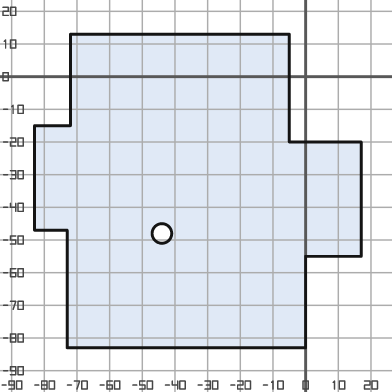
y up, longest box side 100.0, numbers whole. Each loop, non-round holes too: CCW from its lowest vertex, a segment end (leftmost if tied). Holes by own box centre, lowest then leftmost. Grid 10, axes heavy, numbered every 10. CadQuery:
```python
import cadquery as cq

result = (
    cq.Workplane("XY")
    .moveTo(-73.0, -83.0)
    .lineTo(0.0, -83.0)
    .lineTo(0.0, -55.0)
    .lineTo(17.0, -55.0)
    .lineTo(17.0, -20.0)
    .lineTo(-5.0, -20.0)
    .lineTo(-5.0, 13.0)
    .lineTo(-72.0, 13.0)
    .lineTo(-72.0, -15.0)
    .lineTo(-83.0, -15.0)
    .lineTo(-83.0, -47.0)
    .lineTo(-73.0, -47.0)
    .close()
    .moveTo(-44.0, -48.0)
    .circle(3.0)
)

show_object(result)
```